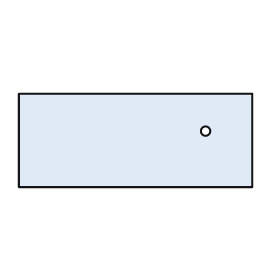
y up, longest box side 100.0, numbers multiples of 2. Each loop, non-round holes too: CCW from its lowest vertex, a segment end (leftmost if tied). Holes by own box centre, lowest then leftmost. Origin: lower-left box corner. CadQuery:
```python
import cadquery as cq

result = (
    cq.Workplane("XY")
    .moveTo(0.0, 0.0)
    .lineTo(100.0, 0.0)
    .lineTo(100.0, 40.0)
    .lineTo(0.0, 40.0)
    .close()
    .moveTo(80.0, 24.0)
    .circle(2.0)
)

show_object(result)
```